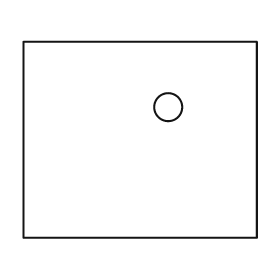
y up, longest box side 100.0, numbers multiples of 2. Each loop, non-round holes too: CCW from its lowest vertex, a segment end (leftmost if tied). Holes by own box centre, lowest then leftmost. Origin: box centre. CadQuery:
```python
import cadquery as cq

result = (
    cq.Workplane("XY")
    .moveTo(-50.0, -42.0)
    .lineTo(50.0, -42.0)
    .lineTo(50.0, 42.0)
    .lineTo(-50.0, 42.0)
    .close()
    .moveTo(12.0, 14.0)
    .circle(6.0)
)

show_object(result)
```